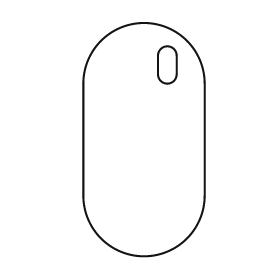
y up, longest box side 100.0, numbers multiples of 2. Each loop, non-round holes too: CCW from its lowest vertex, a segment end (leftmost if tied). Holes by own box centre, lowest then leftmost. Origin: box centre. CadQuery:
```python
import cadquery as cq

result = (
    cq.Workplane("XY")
    .moveTo(-26.0, -24.0)
    .threePointArc((0.0, -50.0), (26.0, -24.0))
    .lineTo(26.0, 24.0)
    .threePointArc((0.0, 50.0), (-26.0, 24.0))
    .close()
    .moveTo(6.0, 28.0)
    .threePointArc((10.0, 24.0), (14.0, 28.0))
    .lineTo(14.0, 36.0)
    .threePointArc((10.0, 40.0), (6.0, 36.0))
    .close()
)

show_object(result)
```